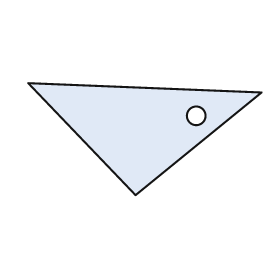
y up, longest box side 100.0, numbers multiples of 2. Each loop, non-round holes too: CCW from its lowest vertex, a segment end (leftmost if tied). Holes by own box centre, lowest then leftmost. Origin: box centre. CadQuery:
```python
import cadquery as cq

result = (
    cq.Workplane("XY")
    .moveTo(-4.0, -24.0)
    .lineTo(50.0, 20.0)
    .lineTo(-50.0, 24.0)
    .close()
    .moveTo(22.0, 10.0)
    .circle(4.0)
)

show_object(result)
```